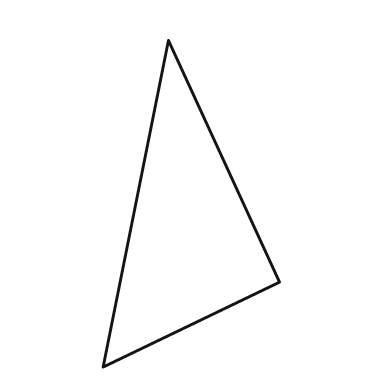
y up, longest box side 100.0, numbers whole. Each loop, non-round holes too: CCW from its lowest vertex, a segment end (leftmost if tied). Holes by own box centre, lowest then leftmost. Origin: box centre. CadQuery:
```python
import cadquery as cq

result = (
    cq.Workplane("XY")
    .moveTo(-27.0, -50.0)
    .lineTo(27.0, -24.0)
    .lineTo(-7.0, 50.0)
    .close()
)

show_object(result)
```